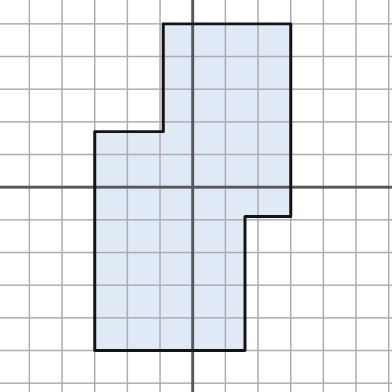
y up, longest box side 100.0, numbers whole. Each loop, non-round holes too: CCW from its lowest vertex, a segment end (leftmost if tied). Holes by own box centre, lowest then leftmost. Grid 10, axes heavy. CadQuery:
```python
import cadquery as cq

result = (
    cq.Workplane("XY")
    .moveTo(-30.0, -50.0)
    .lineTo(16.0, -50.0)
    .lineTo(16.0, -9.0)
    .lineTo(30.0, -9.0)
    .lineTo(30.0, 50.0)
    .lineTo(-9.0, 50.0)
    .lineTo(-9.0, 17.0)
    .lineTo(-30.0, 17.0)
    .close()
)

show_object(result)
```